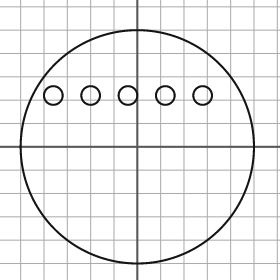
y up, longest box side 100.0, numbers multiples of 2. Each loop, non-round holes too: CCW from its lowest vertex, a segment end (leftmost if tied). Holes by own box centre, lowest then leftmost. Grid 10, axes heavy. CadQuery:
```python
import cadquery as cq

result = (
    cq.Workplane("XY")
    .moveTo(0.0, 0.0)
    .circle(50.0)
    .moveTo(-36.0, 22.0)
    .circle(4.0)
    .moveTo(-20.0, 22.0)
    .circle(4.0)
    .moveTo(-4.0, 22.0)
    .circle(4.0)
    .moveTo(12.0, 22.0)
    .circle(4.0)
    .moveTo(28.0, 22.0)
    .circle(4.0)
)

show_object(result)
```